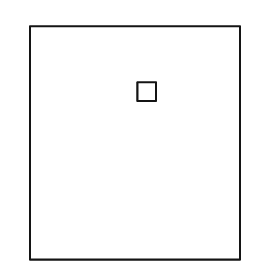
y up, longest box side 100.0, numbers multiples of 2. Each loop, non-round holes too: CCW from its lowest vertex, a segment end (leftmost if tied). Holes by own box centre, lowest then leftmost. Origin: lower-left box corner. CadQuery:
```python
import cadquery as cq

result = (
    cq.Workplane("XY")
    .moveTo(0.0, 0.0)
    .lineTo(90.0, 0.0)
    .lineTo(90.0, 100.0)
    .lineTo(0.0, 100.0)
    .close()
    .moveTo(46.0, 68.0)
    .lineTo(54.0, 68.0)
    .lineTo(54.0, 76.0)
    .lineTo(46.0, 76.0)
    .close()
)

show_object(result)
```